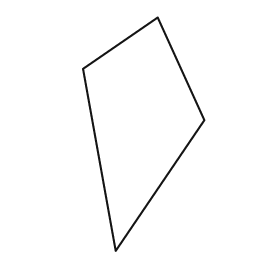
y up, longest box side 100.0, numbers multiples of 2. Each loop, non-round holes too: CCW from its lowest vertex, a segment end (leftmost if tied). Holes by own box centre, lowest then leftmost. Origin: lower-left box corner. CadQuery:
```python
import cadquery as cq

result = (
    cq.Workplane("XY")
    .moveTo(14.0, 0.0)
    .lineTo(52.0, 56.0)
    .lineTo(32.0, 100.0)
    .lineTo(0.0, 78.0)
    .close()
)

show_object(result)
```